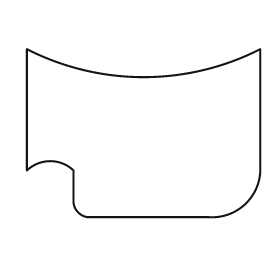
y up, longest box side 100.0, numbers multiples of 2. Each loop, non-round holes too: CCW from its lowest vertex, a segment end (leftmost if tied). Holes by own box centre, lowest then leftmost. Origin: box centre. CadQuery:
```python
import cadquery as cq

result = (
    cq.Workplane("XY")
    .moveTo(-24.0, -36.0)
    .lineTo(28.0, -36.0)
    .threePointArc((44.0, -30.0), (50.0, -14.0))
    .lineTo(50.0, 36.0)
    .threePointArc((0.0, 24.0), (-50.0, 36.0))
    .lineTo(-50.0, -16.0)
    .threePointArc((-40.0, -12.0), (-30.0, -16.0))
    .lineTo(-30.0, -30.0)
    .threePointArc((-28.0, -34.0), (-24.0, -36.0))
    .close()
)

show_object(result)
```